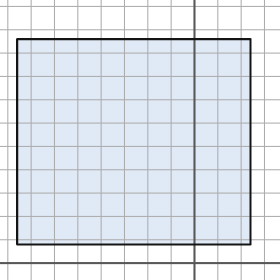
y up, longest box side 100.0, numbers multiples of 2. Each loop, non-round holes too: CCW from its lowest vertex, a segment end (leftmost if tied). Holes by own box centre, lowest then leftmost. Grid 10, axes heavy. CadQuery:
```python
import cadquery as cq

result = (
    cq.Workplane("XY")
    .moveTo(-76.0, 8.0)
    .lineTo(24.0, 8.0)
    .lineTo(24.0, 96.0)
    .lineTo(-76.0, 96.0)
    .close()
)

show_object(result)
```